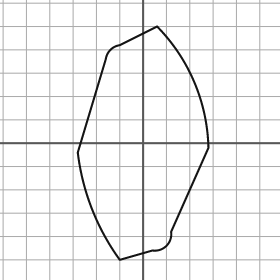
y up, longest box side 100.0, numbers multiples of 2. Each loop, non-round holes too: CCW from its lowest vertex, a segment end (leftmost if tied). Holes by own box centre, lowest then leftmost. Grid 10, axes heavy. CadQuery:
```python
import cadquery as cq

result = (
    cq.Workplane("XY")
    .moveTo(-10.0, -50.0)
    .lineTo(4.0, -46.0)
    .threePointArc((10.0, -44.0), (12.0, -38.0))
    .lineTo(28.0, -2.0)
    .threePointArc((22.0, 26.0), (6.0, 50.0))
    .lineTo(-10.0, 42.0)
    .threePointArc((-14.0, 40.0), (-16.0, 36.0))
    .lineTo(-28.0, -4.0)
    .threePointArc((-22.0, -28.0), (-10.0, -50.0))
    .close()
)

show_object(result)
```